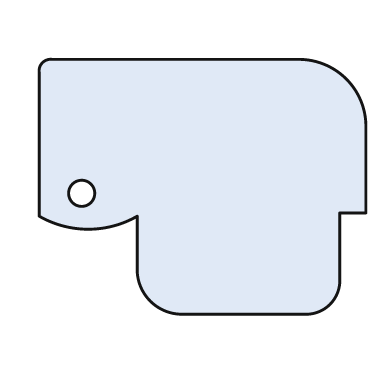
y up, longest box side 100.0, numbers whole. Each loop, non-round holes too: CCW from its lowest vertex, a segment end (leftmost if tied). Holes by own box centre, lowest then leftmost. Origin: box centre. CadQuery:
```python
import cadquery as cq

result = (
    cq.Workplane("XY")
    .moveTo(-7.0, -39.0)
    .lineTo(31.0, -39.0)
    .threePointArc((39.0, -36.0), (42.0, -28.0))
    .lineTo(42.0, -8.0)
    .lineTo(50.0, -8.0)
    .lineTo(50.0, 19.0)
    .threePointArc((44.0, 33.0), (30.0, 39.0))
    .lineTo(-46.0, 39.0)
    .threePointArc((-49.0, 38.0), (-50.0, 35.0))
    .lineTo(-50.0, -9.0)
    .threePointArc((-35.0, -13.0), (-20.0, -9.0))
    .lineTo(-20.0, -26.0)
    .threePointArc((-16.0, -35.0), (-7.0, -39.0))
    .close()
    .moveTo(-37.0, -2.0)
    .circle(4.0)
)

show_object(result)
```